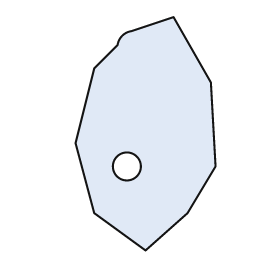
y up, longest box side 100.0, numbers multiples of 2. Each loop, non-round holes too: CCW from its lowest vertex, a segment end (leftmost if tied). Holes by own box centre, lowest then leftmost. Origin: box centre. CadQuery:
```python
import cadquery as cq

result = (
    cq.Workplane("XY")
    .moveTo(0.0, -50.0)
    .lineTo(18.0, -34.0)
    .lineTo(30.0, -14.0)
    .lineTo(28.0, 22.0)
    .lineTo(12.0, 50.0)
    .lineTo(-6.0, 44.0)
    .threePointArc((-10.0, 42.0), (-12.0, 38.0))
    .lineTo(-22.0, 28.0)
    .lineTo(-30.0, -4.0)
    .lineTo(-22.0, -34.0)
    .close()
    .moveTo(-8.0, -14.0)
    .circle(6.0)
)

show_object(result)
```